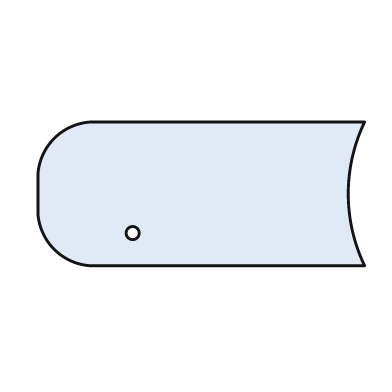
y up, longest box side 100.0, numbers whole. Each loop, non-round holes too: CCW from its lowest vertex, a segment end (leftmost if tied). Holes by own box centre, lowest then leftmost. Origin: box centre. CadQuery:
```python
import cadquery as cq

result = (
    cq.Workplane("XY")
    .moveTo(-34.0, -22.0)
    .lineTo(50.0, -22.0)
    .threePointArc((45.0, 0.0), (50.0, 22.0))
    .lineTo(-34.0, 22.0)
    .threePointArc((-45.0, 17.0), (-50.0, 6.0))
    .lineTo(-50.0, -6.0)
    .threePointArc((-45.0, -17.0), (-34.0, -22.0))
    .close()
    .moveTo(-21.0, -12.0)
    .circle(2.0)
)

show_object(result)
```